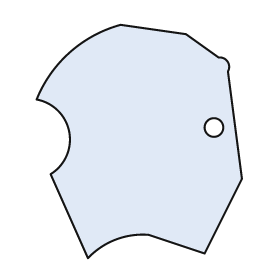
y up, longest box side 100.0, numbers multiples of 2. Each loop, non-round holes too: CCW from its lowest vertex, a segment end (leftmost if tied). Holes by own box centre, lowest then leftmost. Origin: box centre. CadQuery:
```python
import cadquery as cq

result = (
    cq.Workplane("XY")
    .moveTo(-22.0, -50.0)
    .threePointArc((-10.0, -42.0), (4.0, -40.0))
    .lineTo(28.0, -48.0)
    .lineTo(44.0, -16.0)
    .lineTo(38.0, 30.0)
    .threePointArc((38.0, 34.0), (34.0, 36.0))
    .lineTo(20.0, 46.0)
    .lineTo(-8.0, 50.0)
    .threePointArc((-30.0, 38.0), (-44.0, 18.0))
    .threePointArc((-30.0, 4.0), (-38.0, -14.0))
    .close()
    .moveTo(32.0, 6.0)
    .circle(4.0)
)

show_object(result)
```